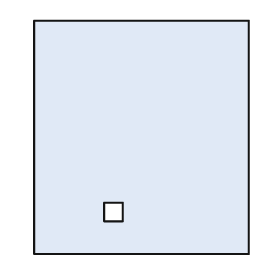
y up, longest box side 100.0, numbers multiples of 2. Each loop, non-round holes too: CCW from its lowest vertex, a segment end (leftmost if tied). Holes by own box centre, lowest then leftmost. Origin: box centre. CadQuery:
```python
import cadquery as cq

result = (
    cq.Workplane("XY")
    .moveTo(-46.0, -50.0)
    .lineTo(46.0, -50.0)
    .lineTo(46.0, 50.0)
    .lineTo(-46.0, 50.0)
    .close()
    .moveTo(-16.0, -36.0)
    .lineTo(-8.0, -36.0)
    .lineTo(-8.0, -28.0)
    .lineTo(-16.0, -28.0)
    .close()
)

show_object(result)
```